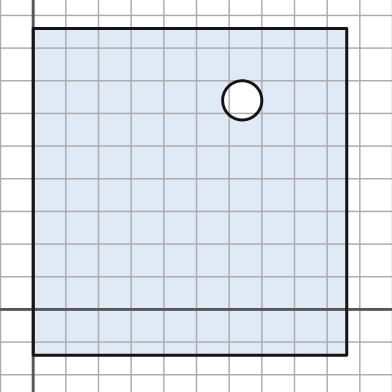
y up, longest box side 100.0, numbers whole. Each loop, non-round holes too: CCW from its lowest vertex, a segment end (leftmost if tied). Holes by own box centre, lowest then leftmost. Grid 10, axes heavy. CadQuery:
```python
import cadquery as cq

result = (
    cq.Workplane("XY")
    .moveTo(0.0, -14.0)
    .lineTo(96.0, -14.0)
    .lineTo(96.0, 86.0)
    .lineTo(0.0, 86.0)
    .close()
    .moveTo(64.0, 64.0)
    .circle(6.0)
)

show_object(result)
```